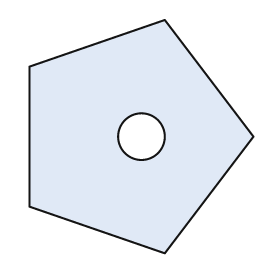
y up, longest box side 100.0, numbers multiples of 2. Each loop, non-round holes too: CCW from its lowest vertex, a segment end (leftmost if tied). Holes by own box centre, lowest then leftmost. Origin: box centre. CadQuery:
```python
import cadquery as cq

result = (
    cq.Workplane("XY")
    .moveTo(10.0, -50.0)
    .lineTo(48.0, 0.0)
    .lineTo(10.0, 50.0)
    .lineTo(-48.0, 30.0)
    .lineTo(-48.0, -30.0)
    .close()
    .moveTo(0.0, 0.0)
    .circle(10.0)
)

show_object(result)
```